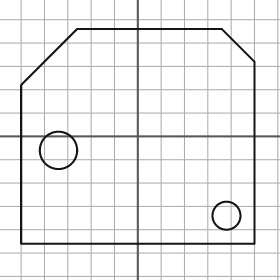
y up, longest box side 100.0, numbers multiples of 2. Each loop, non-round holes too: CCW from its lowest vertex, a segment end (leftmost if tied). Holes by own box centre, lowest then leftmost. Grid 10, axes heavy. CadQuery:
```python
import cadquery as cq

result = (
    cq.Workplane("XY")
    .moveTo(-50.0, -46.0)
    .lineTo(50.0, -46.0)
    .lineTo(50.0, 32.0)
    .lineTo(36.0, 46.0)
    .lineTo(-26.0, 46.0)
    .lineTo(-50.0, 22.0)
    .close()
    .moveTo(38.0, -34.0)
    .circle(6.0)
    .moveTo(-34.0, -6.0)
    .circle(8.0)
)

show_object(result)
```